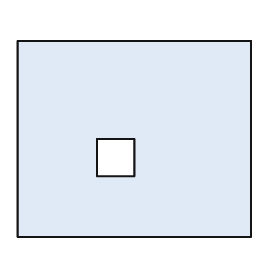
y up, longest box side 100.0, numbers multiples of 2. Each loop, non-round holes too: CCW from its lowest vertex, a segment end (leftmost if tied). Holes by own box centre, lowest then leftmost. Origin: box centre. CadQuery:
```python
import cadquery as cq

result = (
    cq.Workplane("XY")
    .moveTo(-50.0, -42.0)
    .lineTo(50.0, -42.0)
    .lineTo(50.0, 42.0)
    .lineTo(-50.0, 42.0)
    .close()
    .moveTo(-16.0, -16.0)
    .lineTo(0.0, -16.0)
    .lineTo(0.0, 0.0)
    .lineTo(-16.0, 0.0)
    .close()
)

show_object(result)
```